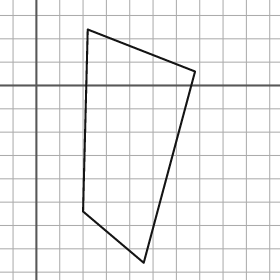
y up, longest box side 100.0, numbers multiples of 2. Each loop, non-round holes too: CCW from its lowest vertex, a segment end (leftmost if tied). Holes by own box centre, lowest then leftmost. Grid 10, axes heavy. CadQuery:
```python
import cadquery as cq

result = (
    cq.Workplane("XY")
    .moveTo(46.0, -76.0)
    .lineTo(68.0, 6.0)
    .lineTo(22.0, 24.0)
    .lineTo(20.0, -54.0)
    .close()
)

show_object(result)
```